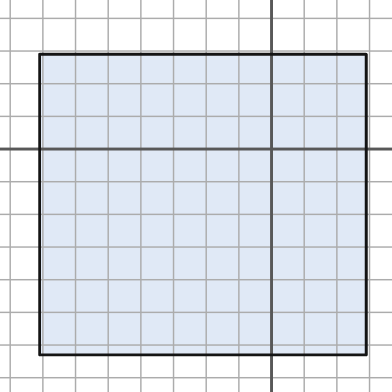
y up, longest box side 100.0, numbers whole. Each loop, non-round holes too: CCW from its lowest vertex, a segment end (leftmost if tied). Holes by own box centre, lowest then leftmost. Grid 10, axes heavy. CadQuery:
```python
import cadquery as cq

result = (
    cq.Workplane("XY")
    .moveTo(-71.0, -63.0)
    .lineTo(29.0, -63.0)
    .lineTo(29.0, 29.0)
    .lineTo(-71.0, 29.0)
    .close()
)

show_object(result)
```